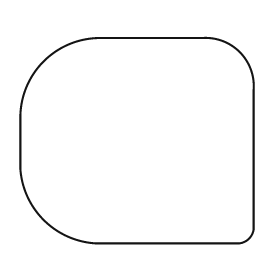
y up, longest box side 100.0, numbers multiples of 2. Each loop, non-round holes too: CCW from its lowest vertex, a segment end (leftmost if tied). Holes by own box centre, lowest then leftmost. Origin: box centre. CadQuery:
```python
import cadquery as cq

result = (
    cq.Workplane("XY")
    .moveTo(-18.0, -44.0)
    .lineTo(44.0, -44.0)
    .threePointArc((48.0, -42.0), (50.0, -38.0))
    .lineTo(50.0, 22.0)
    .threePointArc((44.0, 38.0), (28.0, 44.0))
    .lineTo(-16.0, 44.0)
    .threePointArc((-40.0, 34.0), (-50.0, 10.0))
    .lineTo(-50.0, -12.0)
    .threePointArc((-40.0, -34.0), (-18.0, -44.0))
    .close()
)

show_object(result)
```